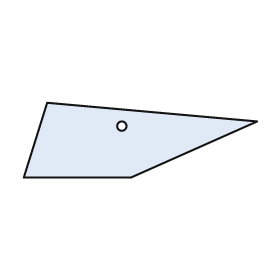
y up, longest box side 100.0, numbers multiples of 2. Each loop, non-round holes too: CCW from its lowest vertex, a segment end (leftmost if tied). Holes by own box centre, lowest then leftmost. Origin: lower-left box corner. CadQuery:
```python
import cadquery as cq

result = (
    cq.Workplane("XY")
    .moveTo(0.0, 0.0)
    .lineTo(46.0, 0.0)
    .lineTo(100.0, 24.0)
    .lineTo(10.0, 32.0)
    .close()
    .moveTo(42.0, 22.0)
    .circle(2.0)
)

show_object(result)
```